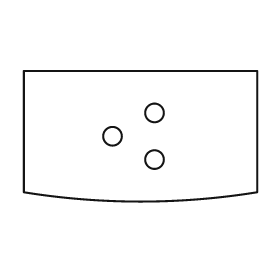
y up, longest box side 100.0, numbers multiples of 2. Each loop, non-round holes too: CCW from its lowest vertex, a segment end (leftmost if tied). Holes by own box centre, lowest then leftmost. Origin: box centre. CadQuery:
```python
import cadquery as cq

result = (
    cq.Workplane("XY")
    .moveTo(-50.0, -24.0)
    .threePointArc((0.0, -28.0), (50.0, -24.0))
    .lineTo(50.0, 28.0)
    .lineTo(-50.0, 28.0)
    .close()
    .moveTo(6.0, -10.0)
    .circle(4.0)
    .moveTo(-12.0, 0.0)
    .circle(4.0)
    .moveTo(6.0, 10.0)
    .circle(4.0)
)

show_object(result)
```